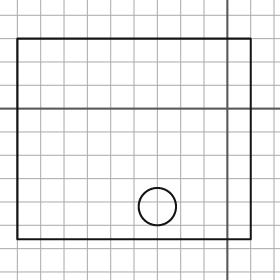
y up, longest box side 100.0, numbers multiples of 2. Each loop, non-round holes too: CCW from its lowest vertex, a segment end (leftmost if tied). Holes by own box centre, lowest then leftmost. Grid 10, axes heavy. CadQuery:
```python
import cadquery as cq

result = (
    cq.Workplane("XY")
    .moveTo(-90.0, -56.0)
    .lineTo(10.0, -56.0)
    .lineTo(10.0, 30.0)
    .lineTo(-90.0, 30.0)
    .close()
    .moveTo(-30.0, -42.0)
    .circle(8.0)
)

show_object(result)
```